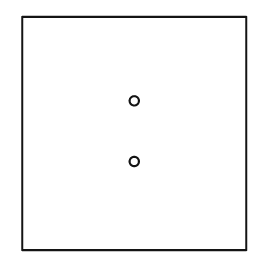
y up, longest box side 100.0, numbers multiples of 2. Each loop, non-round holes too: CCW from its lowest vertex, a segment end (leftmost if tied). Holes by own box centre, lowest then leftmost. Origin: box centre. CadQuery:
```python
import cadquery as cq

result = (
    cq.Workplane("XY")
    .moveTo(-48.0, -50.0)
    .lineTo(48.0, -50.0)
    .lineTo(48.0, 50.0)
    .lineTo(-48.0, 50.0)
    .close()
    .moveTo(0.0, -12.0)
    .circle(2.0)
    .moveTo(0.0, 14.0)
    .circle(2.0)
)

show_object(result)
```